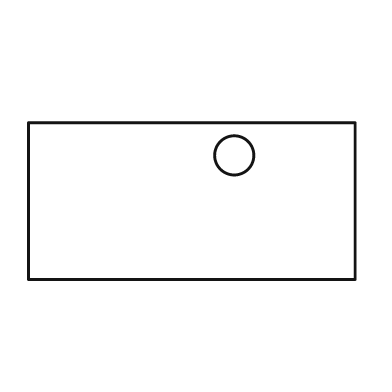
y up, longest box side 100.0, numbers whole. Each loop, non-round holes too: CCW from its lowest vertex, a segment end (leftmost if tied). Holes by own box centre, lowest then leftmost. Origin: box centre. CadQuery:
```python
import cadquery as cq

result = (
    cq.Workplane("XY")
    .moveTo(-50.0, -24.0)
    .lineTo(50.0, -24.0)
    .lineTo(50.0, 24.0)
    .lineTo(-50.0, 24.0)
    .close()
    .moveTo(13.0, 14.0)
    .circle(6.0)
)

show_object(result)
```